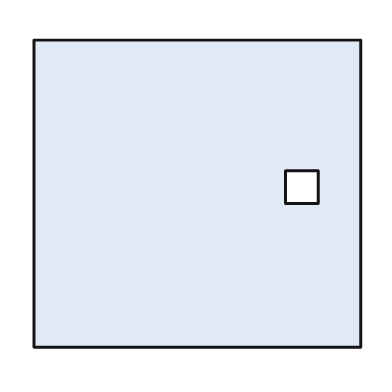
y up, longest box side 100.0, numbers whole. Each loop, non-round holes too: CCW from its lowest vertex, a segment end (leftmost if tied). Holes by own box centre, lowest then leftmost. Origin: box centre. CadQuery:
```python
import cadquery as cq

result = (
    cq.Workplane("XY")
    .moveTo(-50.0, -47.0)
    .lineTo(50.0, -47.0)
    .lineTo(50.0, 47.0)
    .lineTo(-50.0, 47.0)
    .close()
    .moveTo(27.0, -3.0)
    .lineTo(37.0, -3.0)
    .lineTo(37.0, 7.0)
    .lineTo(27.0, 7.0)
    .close()
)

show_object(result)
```